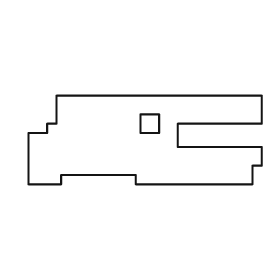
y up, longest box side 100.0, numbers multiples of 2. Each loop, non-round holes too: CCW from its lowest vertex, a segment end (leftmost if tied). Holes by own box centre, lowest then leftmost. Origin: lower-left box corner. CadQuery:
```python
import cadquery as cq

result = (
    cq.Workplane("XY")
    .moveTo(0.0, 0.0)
    .lineTo(14.0, 0.0)
    .lineTo(14.0, 4.0)
    .lineTo(46.0, 4.0)
    .lineTo(46.0, 0.0)
    .lineTo(96.0, 0.0)
    .lineTo(96.0, 8.0)
    .lineTo(100.0, 8.0)
    .lineTo(100.0, 16.0)
    .lineTo(64.0, 16.0)
    .lineTo(64.0, 26.0)
    .lineTo(100.0, 26.0)
    .lineTo(100.0, 38.0)
    .lineTo(12.0, 38.0)
    .lineTo(12.0, 26.0)
    .lineTo(8.0, 26.0)
    .lineTo(8.0, 22.0)
    .lineTo(0.0, 22.0)
    .close()
    .moveTo(48.0, 22.0)
    .lineTo(56.0, 22.0)
    .lineTo(56.0, 30.0)
    .lineTo(48.0, 30.0)
    .close()
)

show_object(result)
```